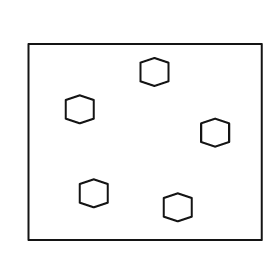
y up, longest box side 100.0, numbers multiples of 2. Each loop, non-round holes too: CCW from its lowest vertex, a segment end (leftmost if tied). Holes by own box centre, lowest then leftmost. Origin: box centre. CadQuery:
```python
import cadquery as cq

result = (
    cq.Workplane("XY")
    .moveTo(-50.0, -42.0)
    .lineTo(50.0, -42.0)
    .lineTo(50.0, 42.0)
    .lineTo(-50.0, 42.0)
    .close()
    .moveTo(14.0, -34.0)
    .lineTo(20.0, -32.0)
    .lineTo(20.0, -24.0)
    .lineTo(14.0, -22.0)
    .lineTo(8.0, -24.0)
    .lineTo(8.0, -32.0)
    .close()
    .moveTo(-22.0, -28.0)
    .lineTo(-16.0, -26.0)
    .lineTo(-16.0, -18.0)
    .lineTo(-22.0, -16.0)
    .lineTo(-28.0, -18.0)
    .lineTo(-28.0, -26.0)
    .close()
    .moveTo(30.0, -2.0)
    .lineTo(36.0, 0.0)
    .lineTo(36.0, 8.0)
    .lineTo(30.0, 10.0)
    .lineTo(24.0, 8.0)
    .lineTo(24.0, 0.0)
    .close()
    .moveTo(-28.0, 8.0)
    .lineTo(-22.0, 10.0)
    .lineTo(-22.0, 18.0)
    .lineTo(-28.0, 20.0)
    .lineTo(-34.0, 18.0)
    .lineTo(-34.0, 10.0)
    .close()
    .moveTo(4.0, 24.0)
    .lineTo(10.0, 26.0)
    .lineTo(10.0, 34.0)
    .lineTo(4.0, 36.0)
    .lineTo(-2.0, 34.0)
    .lineTo(-2.0, 26.0)
    .close()
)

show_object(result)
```